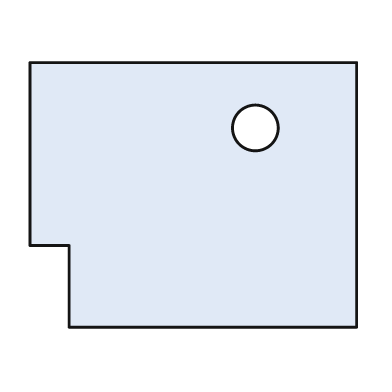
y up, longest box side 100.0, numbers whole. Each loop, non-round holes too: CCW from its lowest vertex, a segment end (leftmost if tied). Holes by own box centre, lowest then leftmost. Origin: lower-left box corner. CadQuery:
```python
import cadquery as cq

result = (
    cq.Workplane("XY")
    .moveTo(12.0, 0.0)
    .lineTo(100.0, 0.0)
    .lineTo(100.0, 81.0)
    .lineTo(0.0, 81.0)
    .lineTo(0.0, 25.0)
    .lineTo(12.0, 25.0)
    .close()
    .moveTo(69.0, 61.0)
    .circle(7.0)
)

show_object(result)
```